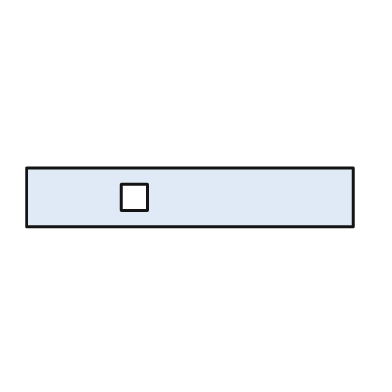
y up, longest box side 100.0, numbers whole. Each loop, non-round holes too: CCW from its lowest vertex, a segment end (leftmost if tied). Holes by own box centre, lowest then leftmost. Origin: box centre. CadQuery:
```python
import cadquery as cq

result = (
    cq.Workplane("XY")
    .moveTo(-50.0, -9.0)
    .lineTo(50.0, -9.0)
    .lineTo(50.0, 9.0)
    .lineTo(-50.0, 9.0)
    .close()
    .moveTo(-21.0, -4.0)
    .lineTo(-13.0, -4.0)
    .lineTo(-13.0, 4.0)
    .lineTo(-21.0, 4.0)
    .close()
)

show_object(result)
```